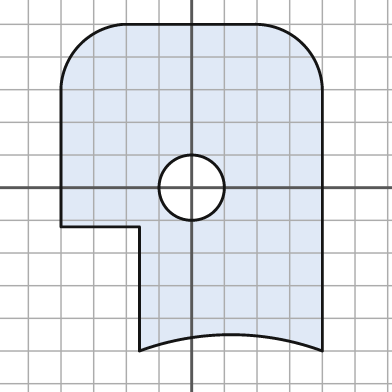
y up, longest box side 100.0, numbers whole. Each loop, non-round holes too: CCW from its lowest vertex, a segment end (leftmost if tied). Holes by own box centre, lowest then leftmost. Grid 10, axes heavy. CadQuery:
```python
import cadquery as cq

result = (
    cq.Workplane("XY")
    .moveTo(-16.0, -50.0)
    .threePointArc((12.0, -45.0), (40.0, -50.0))
    .lineTo(40.0, 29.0)
    .threePointArc((34.0, 44.0), (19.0, 50.0))
    .lineTo(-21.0, 50.0)
    .threePointArc((-34.0, 44.0), (-40.0, 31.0))
    .lineTo(-40.0, -12.0)
    .lineTo(-16.0, -12.0)
    .close()
    .moveTo(0.0, 0.0)
    .circle(10.0)
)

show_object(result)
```